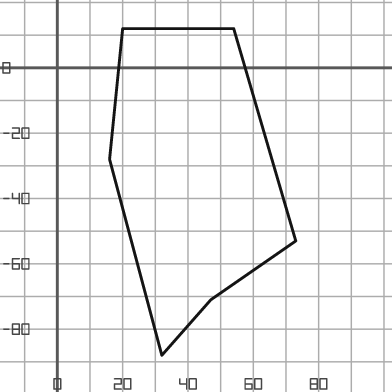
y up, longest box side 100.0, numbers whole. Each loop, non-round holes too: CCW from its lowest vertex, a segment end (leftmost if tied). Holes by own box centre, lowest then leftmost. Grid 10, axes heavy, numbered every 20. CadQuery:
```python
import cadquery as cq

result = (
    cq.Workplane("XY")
    .moveTo(32.0, -88.0)
    .lineTo(47.0, -71.0)
    .lineTo(73.0, -53.0)
    .lineTo(54.0, 12.0)
    .lineTo(20.0, 12.0)
    .lineTo(16.0, -28.0)
    .close()
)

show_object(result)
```